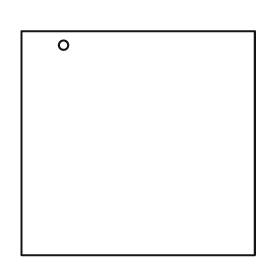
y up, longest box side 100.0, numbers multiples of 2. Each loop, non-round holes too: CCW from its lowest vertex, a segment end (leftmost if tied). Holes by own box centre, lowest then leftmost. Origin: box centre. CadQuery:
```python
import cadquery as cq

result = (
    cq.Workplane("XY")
    .moveTo(-50.0, -48.0)
    .lineTo(50.0, -48.0)
    .lineTo(50.0, 48.0)
    .lineTo(-50.0, 48.0)
    .close()
    .moveTo(-32.0, 42.0)
    .circle(2.0)
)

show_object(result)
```